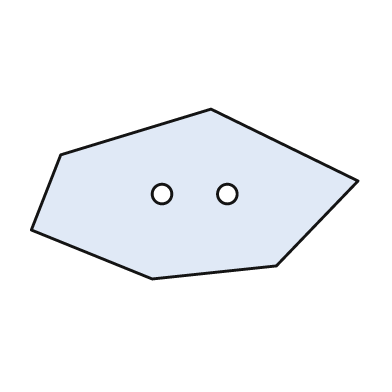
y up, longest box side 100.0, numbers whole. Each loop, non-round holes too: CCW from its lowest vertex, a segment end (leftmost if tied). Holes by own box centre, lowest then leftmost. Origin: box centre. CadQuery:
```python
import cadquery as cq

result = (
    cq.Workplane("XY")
    .moveTo(-13.0, -26.0)
    .lineTo(25.0, -22.0)
    .lineTo(50.0, 4.0)
    .lineTo(5.0, 26.0)
    .lineTo(-41.0, 12.0)
    .lineTo(-50.0, -11.0)
    .close()
    .moveTo(-10.0, 0.0)
    .circle(3.0)
    .moveTo(10.0, 0.0)
    .circle(3.0)
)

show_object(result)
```